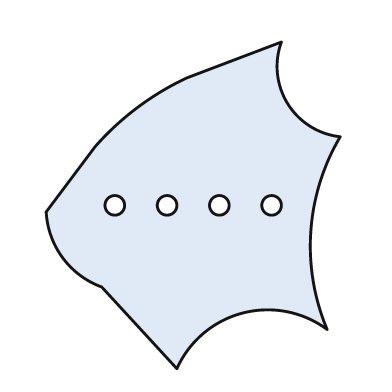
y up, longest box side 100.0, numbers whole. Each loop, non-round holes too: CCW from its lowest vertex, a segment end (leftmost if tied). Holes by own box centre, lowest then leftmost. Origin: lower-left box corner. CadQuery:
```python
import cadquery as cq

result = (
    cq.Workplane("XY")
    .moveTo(40.0, 0.0)
    .threePointArc((60.0, 17.0), (86.0, 12.0))
    .threePointArc((81.0, 42.0), (90.0, 71.0))
    .threePointArc((74.0, 81.0), (72.0, 100.0))
    .lineTo(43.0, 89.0)
    .threePointArc((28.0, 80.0), (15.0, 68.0))
    .lineTo(0.0, 48.0)
    .threePointArc((5.0, 34.0), (17.0, 25.0))
    .close()
    .moveTo(21.0, 50.0)
    .circle(3.0)
    .moveTo(37.0, 50.0)
    .circle(3.0)
    .moveTo(53.0, 50.0)
    .circle(3.0)
    .moveTo(69.0, 50.0)
    .circle(3.0)
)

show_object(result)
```